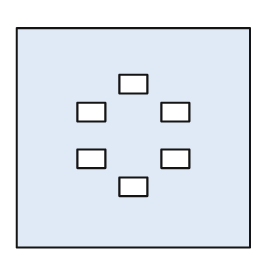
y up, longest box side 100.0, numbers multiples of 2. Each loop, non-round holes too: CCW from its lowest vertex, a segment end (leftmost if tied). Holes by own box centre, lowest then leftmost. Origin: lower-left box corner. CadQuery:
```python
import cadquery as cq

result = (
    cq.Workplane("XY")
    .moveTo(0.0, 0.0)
    .lineTo(100.0, 0.0)
    .lineTo(100.0, 94.0)
    .lineTo(0.0, 94.0)
    .close()
    .moveTo(44.0, 22.0)
    .lineTo(56.0, 22.0)
    .lineTo(56.0, 30.0)
    .lineTo(44.0, 30.0)
    .close()
    .moveTo(26.0, 34.0)
    .lineTo(38.0, 34.0)
    .lineTo(38.0, 42.0)
    .lineTo(26.0, 42.0)
    .close()
    .moveTo(62.0, 34.0)
    .lineTo(74.0, 34.0)
    .lineTo(74.0, 42.0)
    .lineTo(62.0, 42.0)
    .close()
    .moveTo(26.0, 54.0)
    .lineTo(38.0, 54.0)
    .lineTo(38.0, 62.0)
    .lineTo(26.0, 62.0)
    .close()
    .moveTo(62.0, 54.0)
    .lineTo(74.0, 54.0)
    .lineTo(74.0, 62.0)
    .lineTo(62.0, 62.0)
    .close()
    .moveTo(44.0, 66.0)
    .lineTo(56.0, 66.0)
    .lineTo(56.0, 74.0)
    .lineTo(44.0, 74.0)
    .close()
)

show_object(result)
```